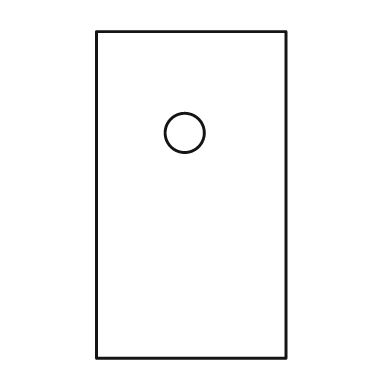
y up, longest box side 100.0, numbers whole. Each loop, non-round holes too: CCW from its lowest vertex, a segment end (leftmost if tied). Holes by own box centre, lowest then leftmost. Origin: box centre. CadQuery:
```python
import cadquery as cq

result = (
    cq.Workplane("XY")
    .moveTo(-29.0, -50.0)
    .lineTo(29.0, -50.0)
    .lineTo(29.0, 50.0)
    .lineTo(-29.0, 50.0)
    .close()
    .moveTo(-2.0, 19.0)
    .circle(6.0)
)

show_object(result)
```